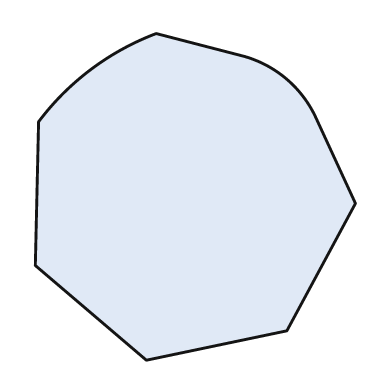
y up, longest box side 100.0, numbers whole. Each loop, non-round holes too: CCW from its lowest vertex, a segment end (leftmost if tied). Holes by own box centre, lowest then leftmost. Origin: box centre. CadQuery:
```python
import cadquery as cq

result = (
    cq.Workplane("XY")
    .moveTo(-15.0, -50.0)
    .lineTo(28.0, -41.0)
    .lineTo(49.0, -2.0)
    .lineTo(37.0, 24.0)
    .threePointArc((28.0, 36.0), (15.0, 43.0))
    .lineTo(-12.0, 50.0)
    .threePointArc((-32.0, 39.0), (-48.0, 23.0))
    .lineTo(-49.0, -21.0)
    .close()
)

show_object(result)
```